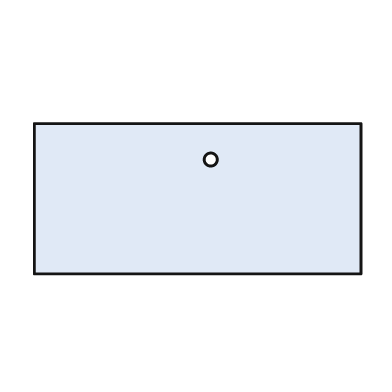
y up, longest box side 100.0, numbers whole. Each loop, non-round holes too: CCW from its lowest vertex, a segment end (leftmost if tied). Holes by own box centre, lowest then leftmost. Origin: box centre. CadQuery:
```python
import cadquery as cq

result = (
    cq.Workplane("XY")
    .moveTo(-50.0, -23.0)
    .lineTo(50.0, -23.0)
    .lineTo(50.0, 23.0)
    .lineTo(-50.0, 23.0)
    .close()
    .moveTo(4.0, 12.0)
    .circle(2.0)
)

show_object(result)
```